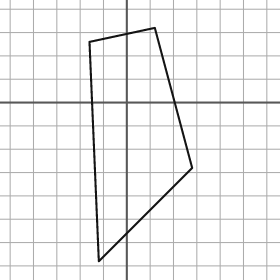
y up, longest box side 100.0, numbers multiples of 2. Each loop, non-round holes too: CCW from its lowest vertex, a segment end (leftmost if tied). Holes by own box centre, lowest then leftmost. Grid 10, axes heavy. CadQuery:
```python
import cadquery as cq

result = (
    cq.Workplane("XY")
    .moveTo(-12.0, -68.0)
    .lineTo(28.0, -28.0)
    .lineTo(12.0, 32.0)
    .lineTo(-16.0, 26.0)
    .close()
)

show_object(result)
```